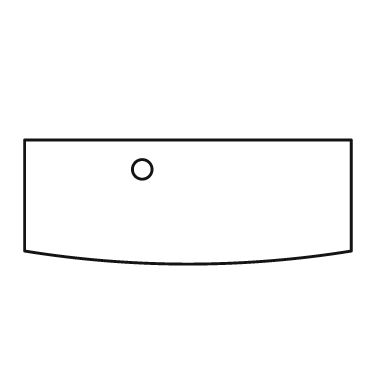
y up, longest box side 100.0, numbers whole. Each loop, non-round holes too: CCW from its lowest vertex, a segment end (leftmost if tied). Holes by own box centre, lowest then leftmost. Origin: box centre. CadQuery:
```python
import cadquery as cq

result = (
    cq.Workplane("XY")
    .moveTo(-50.0, -15.0)
    .threePointArc((0.0, -19.0), (50.0, -15.0))
    .lineTo(50.0, 19.0)
    .lineTo(-50.0, 19.0)
    .close()
    .moveTo(-14.0, 10.0)
    .circle(3.0)
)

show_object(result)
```